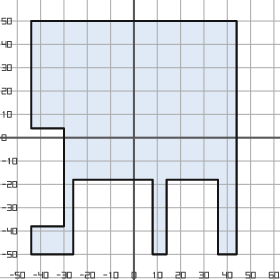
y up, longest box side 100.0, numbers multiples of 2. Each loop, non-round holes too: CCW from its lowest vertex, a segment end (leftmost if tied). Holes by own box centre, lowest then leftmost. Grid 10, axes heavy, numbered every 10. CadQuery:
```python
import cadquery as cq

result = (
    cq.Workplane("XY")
    .moveTo(-44.0, -50.0)
    .lineTo(-26.0, -50.0)
    .lineTo(-26.0, -18.0)
    .lineTo(8.0, -18.0)
    .lineTo(8.0, -50.0)
    .lineTo(14.0, -50.0)
    .lineTo(14.0, -18.0)
    .lineTo(36.0, -18.0)
    .lineTo(36.0, -50.0)
    .lineTo(44.0, -50.0)
    .lineTo(44.0, 50.0)
    .lineTo(-44.0, 50.0)
    .lineTo(-44.0, 4.0)
    .lineTo(-30.0, 4.0)
    .lineTo(-30.0, -38.0)
    .lineTo(-44.0, -38.0)
    .close()
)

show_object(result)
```